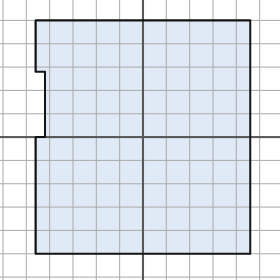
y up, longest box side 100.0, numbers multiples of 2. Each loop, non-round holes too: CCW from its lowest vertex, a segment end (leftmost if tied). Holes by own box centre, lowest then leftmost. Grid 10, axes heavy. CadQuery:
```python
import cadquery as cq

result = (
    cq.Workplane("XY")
    .moveTo(-46.0, -50.0)
    .lineTo(46.0, -50.0)
    .lineTo(46.0, 50.0)
    .lineTo(-46.0, 50.0)
    .lineTo(-46.0, 28.0)
    .lineTo(-42.0, 28.0)
    .lineTo(-42.0, 0.0)
    .lineTo(-46.0, 0.0)
    .close()
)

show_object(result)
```